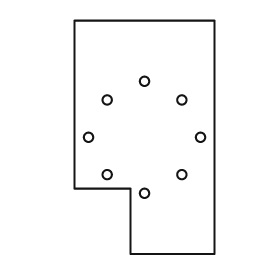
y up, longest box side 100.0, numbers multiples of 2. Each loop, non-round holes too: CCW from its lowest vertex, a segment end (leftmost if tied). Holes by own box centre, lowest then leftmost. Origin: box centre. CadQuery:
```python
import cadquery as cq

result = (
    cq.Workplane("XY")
    .moveTo(-6.0, -50.0)
    .lineTo(30.0, -50.0)
    .lineTo(30.0, 50.0)
    .lineTo(-30.0, 50.0)
    .lineTo(-30.0, -22.0)
    .lineTo(-6.0, -22.0)
    .close()
    .moveTo(0.0, -24.0)
    .circle(2.0)
    .moveTo(-16.0, -16.0)
    .circle(2.0)
    .moveTo(16.0, -16.0)
    .circle(2.0)
    .moveTo(-24.0, 0.0)
    .circle(2.0)
    .moveTo(24.0, 0.0)
    .circle(2.0)
    .moveTo(-16.0, 16.0)
    .circle(2.0)
    .moveTo(16.0, 16.0)
    .circle(2.0)
    .moveTo(0.0, 24.0)
    .circle(2.0)
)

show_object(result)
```